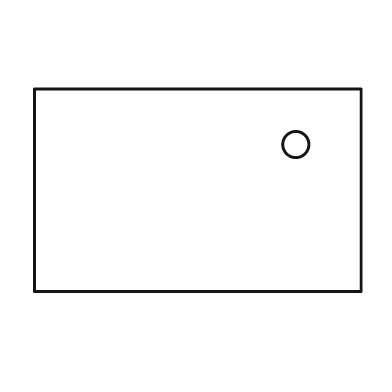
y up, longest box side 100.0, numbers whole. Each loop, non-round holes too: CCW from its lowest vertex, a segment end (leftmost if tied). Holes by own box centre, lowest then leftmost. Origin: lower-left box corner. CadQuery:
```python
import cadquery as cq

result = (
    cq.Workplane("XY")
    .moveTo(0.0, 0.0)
    .lineTo(100.0, 0.0)
    .lineTo(100.0, 62.0)
    .lineTo(0.0, 62.0)
    .close()
    .moveTo(80.0, 45.0)
    .circle(4.0)
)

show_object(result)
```